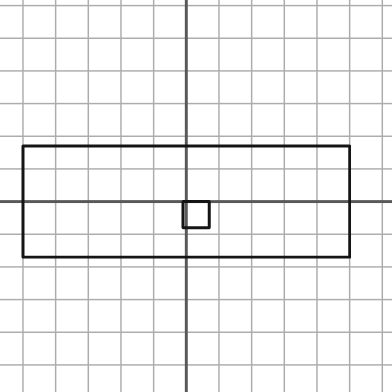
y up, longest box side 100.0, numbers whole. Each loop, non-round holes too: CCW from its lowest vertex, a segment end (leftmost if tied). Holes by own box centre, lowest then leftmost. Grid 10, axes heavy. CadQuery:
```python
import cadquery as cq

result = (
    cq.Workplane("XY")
    .moveTo(-50.0, -17.0)
    .lineTo(50.0, -17.0)
    .lineTo(50.0, 17.0)
    .lineTo(-50.0, 17.0)
    .close()
    .moveTo(-1.0, -8.0)
    .lineTo(7.0, -8.0)
    .lineTo(7.0, 0.0)
    .lineTo(-1.0, 0.0)
    .close()
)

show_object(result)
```